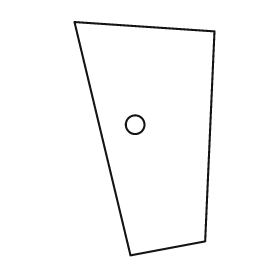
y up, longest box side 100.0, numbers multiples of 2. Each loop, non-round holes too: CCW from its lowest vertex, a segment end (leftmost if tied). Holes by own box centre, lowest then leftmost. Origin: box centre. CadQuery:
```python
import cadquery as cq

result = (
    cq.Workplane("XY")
    .moveTo(-6.0, -50.0)
    .lineTo(26.0, -44.0)
    .lineTo(30.0, 46.0)
    .lineTo(-30.0, 50.0)
    .close()
    .moveTo(-4.0, 6.0)
    .circle(4.0)
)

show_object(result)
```